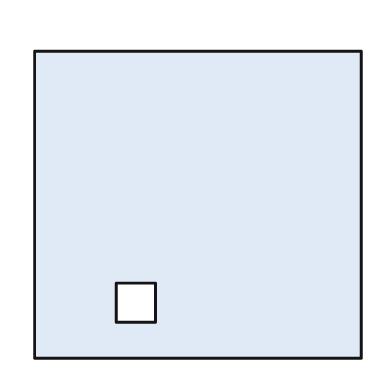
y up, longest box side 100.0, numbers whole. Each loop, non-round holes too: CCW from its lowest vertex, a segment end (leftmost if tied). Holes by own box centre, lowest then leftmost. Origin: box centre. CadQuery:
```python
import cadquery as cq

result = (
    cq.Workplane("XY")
    .moveTo(-50.0, -47.0)
    .lineTo(50.0, -47.0)
    .lineTo(50.0, 47.0)
    .lineTo(-50.0, 47.0)
    .close()
    .moveTo(-25.0, -36.0)
    .lineTo(-13.0, -36.0)
    .lineTo(-13.0, -24.0)
    .lineTo(-25.0, -24.0)
    .close()
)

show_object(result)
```